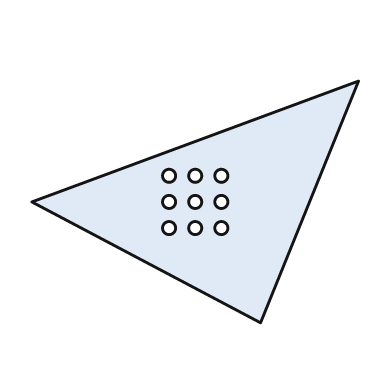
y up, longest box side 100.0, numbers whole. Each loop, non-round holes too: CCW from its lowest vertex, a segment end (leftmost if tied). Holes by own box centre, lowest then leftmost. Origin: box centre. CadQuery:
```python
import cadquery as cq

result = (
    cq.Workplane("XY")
    .moveTo(20.0, -37.0)
    .lineTo(50.0, 37.0)
    .lineTo(-50.0, 0.0)
    .close()
    .moveTo(-8.0, -8.0)
    .circle(2.0)
    .moveTo(0.0, -8.0)
    .circle(2.0)
    .moveTo(8.0, -8.0)
    .circle(2.0)
    .moveTo(-8.0, 0.0)
    .circle(2.0)
    .moveTo(0.0, 0.0)
    .circle(2.0)
    .moveTo(8.0, 0.0)
    .circle(2.0)
    .moveTo(-8.0, 8.0)
    .circle(2.0)
    .moveTo(0.0, 8.0)
    .circle(2.0)
    .moveTo(8.0, 8.0)
    .circle(2.0)
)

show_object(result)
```